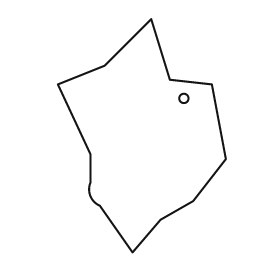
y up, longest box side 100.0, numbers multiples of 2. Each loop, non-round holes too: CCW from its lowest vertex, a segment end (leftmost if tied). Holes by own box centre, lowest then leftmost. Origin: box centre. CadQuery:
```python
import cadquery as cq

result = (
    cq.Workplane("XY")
    .moveTo(-4.0, -50.0)
    .lineTo(8.0, -36.0)
    .lineTo(22.0, -28.0)
    .lineTo(36.0, -10.0)
    .lineTo(30.0, 22.0)
    .lineTo(12.0, 24.0)
    .lineTo(4.0, 50.0)
    .lineTo(-16.0, 30.0)
    .lineTo(-36.0, 22.0)
    .lineTo(-22.0, -8.0)
    .lineTo(-22.0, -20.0)
    .threePointArc((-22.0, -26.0), (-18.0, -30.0))
    .close()
    .moveTo(18.0, 16.0)
    .circle(2.0)
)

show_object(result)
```